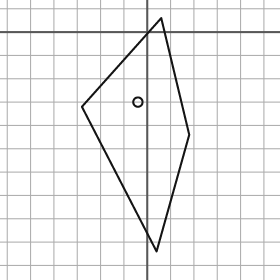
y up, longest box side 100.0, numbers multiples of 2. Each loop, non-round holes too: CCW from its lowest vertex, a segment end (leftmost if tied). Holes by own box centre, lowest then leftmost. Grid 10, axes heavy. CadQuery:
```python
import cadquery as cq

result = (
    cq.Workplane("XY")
    .moveTo(4.0, -94.0)
    .lineTo(18.0, -44.0)
    .lineTo(6.0, 6.0)
    .lineTo(-28.0, -32.0)
    .close()
    .moveTo(-4.0, -30.0)
    .circle(2.0)
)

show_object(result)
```